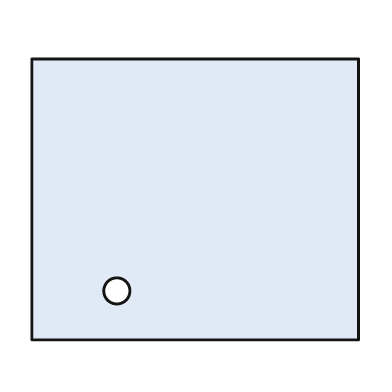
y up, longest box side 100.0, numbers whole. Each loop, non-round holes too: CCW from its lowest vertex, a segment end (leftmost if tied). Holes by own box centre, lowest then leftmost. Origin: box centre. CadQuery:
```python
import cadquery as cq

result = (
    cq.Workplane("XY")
    .moveTo(-50.0, -43.0)
    .lineTo(50.0, -43.0)
    .lineTo(50.0, 43.0)
    .lineTo(-50.0, 43.0)
    .close()
    .moveTo(-24.0, -28.0)
    .circle(4.0)
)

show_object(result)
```